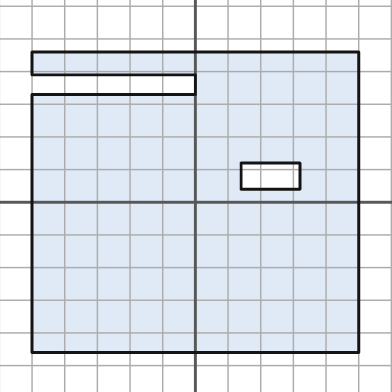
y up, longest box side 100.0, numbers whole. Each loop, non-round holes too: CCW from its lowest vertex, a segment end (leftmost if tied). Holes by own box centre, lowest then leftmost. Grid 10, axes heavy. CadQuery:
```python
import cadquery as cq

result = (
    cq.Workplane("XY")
    .moveTo(-50.0, -46.0)
    .lineTo(50.0, -46.0)
    .lineTo(50.0, 46.0)
    .lineTo(-50.0, 46.0)
    .lineTo(-50.0, 39.0)
    .lineTo(0.0, 39.0)
    .lineTo(0.0, 33.0)
    .lineTo(-50.0, 33.0)
    .close()
    .moveTo(14.0, 4.0)
    .lineTo(32.0, 4.0)
    .lineTo(32.0, 12.0)
    .lineTo(14.0, 12.0)
    .close()
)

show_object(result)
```